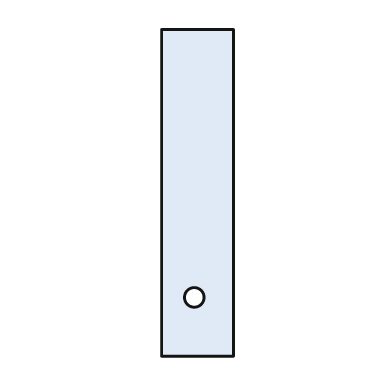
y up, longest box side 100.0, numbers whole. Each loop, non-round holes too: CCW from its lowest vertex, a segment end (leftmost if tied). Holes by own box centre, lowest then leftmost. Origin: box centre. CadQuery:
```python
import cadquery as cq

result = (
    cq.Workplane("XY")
    .moveTo(-11.0, -50.0)
    .lineTo(11.0, -50.0)
    .lineTo(11.0, 50.0)
    .lineTo(-11.0, 50.0)
    .close()
    .moveTo(-1.0, -32.0)
    .circle(3.0)
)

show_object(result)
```